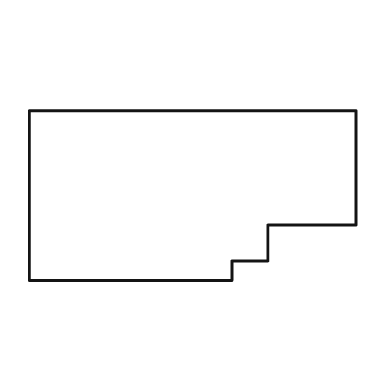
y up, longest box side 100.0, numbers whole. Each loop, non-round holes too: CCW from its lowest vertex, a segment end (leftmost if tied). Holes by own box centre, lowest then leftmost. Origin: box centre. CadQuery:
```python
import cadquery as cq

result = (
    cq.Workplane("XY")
    .moveTo(-50.0, -26.0)
    .lineTo(12.0, -26.0)
    .lineTo(12.0, -20.0)
    .lineTo(23.0, -20.0)
    .lineTo(23.0, -9.0)
    .lineTo(50.0, -9.0)
    .lineTo(50.0, 26.0)
    .lineTo(-50.0, 26.0)
    .close()
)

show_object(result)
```